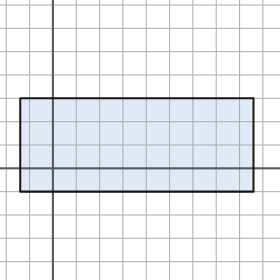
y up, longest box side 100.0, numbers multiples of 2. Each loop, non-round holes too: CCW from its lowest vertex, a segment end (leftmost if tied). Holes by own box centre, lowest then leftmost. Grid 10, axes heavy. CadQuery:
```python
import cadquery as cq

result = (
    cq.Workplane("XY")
    .moveTo(-14.0, -10.0)
    .lineTo(86.0, -10.0)
    .lineTo(86.0, 30.0)
    .lineTo(-14.0, 30.0)
    .close()
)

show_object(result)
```